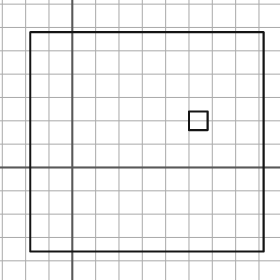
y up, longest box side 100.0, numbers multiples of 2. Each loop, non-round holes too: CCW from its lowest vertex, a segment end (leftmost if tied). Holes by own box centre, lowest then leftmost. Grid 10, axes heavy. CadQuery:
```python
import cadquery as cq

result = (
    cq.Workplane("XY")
    .moveTo(-18.0, -36.0)
    .lineTo(82.0, -36.0)
    .lineTo(82.0, 58.0)
    .lineTo(-18.0, 58.0)
    .close()
    .moveTo(50.0, 16.0)
    .lineTo(58.0, 16.0)
    .lineTo(58.0, 24.0)
    .lineTo(50.0, 24.0)
    .close()
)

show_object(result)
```